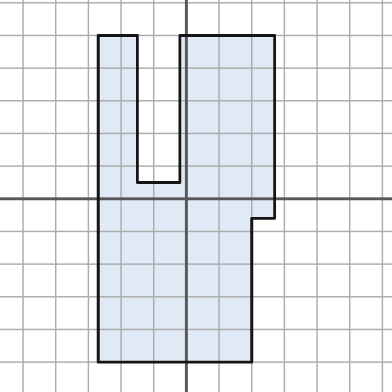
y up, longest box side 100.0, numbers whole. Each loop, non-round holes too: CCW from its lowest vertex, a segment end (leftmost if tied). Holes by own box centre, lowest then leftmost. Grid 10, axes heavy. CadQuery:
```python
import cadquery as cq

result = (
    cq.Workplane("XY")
    .moveTo(-27.0, -50.0)
    .lineTo(20.0, -50.0)
    .lineTo(20.0, -6.0)
    .lineTo(27.0, -6.0)
    .lineTo(27.0, 50.0)
    .lineTo(-2.0, 50.0)
    .lineTo(-2.0, 5.0)
    .lineTo(-15.0, 5.0)
    .lineTo(-15.0, 50.0)
    .lineTo(-27.0, 50.0)
    .close()
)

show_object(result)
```